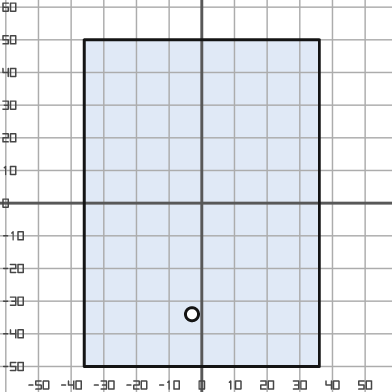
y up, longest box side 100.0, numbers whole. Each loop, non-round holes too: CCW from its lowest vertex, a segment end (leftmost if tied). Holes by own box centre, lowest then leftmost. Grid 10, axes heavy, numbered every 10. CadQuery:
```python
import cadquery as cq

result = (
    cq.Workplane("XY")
    .moveTo(-36.0, -50.0)
    .lineTo(36.0, -50.0)
    .lineTo(36.0, 50.0)
    .lineTo(-36.0, 50.0)
    .close()
    .moveTo(-3.0, -34.0)
    .circle(2.0)
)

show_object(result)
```